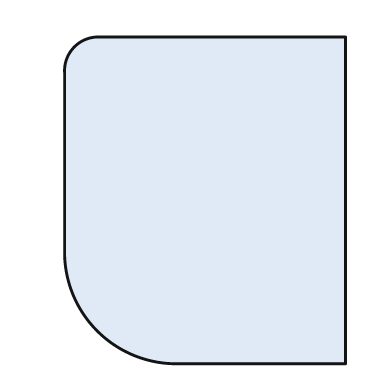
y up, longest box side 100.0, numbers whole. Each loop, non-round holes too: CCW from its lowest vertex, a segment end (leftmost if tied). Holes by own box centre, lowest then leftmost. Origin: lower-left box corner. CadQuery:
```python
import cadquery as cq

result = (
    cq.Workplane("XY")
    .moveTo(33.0, 0.0)
    .lineTo(86.0, 0.0)
    .lineTo(86.0, 100.0)
    .lineTo(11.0, 100.0)
    .threePointArc((3.0, 97.0), (0.0, 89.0))
    .lineTo(0.0, 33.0)
    .threePointArc((10.0, 10.0), (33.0, 0.0))
    .close()
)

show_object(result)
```